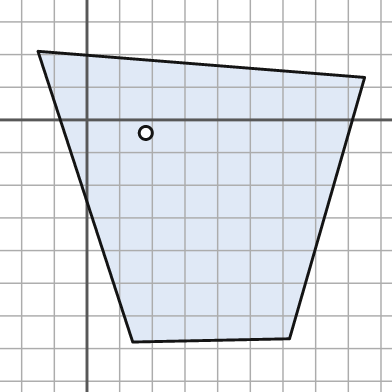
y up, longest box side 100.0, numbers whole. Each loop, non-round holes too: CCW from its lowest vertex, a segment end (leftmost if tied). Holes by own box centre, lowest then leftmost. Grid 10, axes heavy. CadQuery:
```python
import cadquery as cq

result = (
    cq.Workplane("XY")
    .moveTo(14.0, -68.0)
    .lineTo(62.0, -67.0)
    .lineTo(85.0, 13.0)
    .lineTo(-15.0, 21.0)
    .close()
    .moveTo(18.0, -4.0)
    .circle(2.0)
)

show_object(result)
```